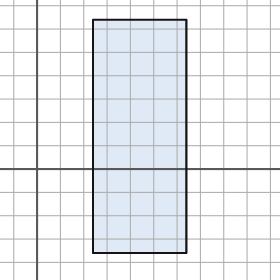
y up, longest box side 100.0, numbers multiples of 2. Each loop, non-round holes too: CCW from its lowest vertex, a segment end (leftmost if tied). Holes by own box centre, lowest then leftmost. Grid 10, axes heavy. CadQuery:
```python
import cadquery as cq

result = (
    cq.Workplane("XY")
    .moveTo(24.0, -36.0)
    .lineTo(64.0, -36.0)
    .lineTo(64.0, 64.0)
    .lineTo(24.0, 64.0)
    .close()
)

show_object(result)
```